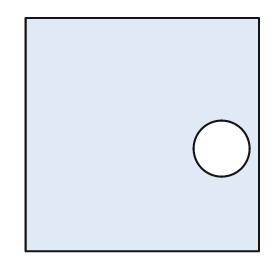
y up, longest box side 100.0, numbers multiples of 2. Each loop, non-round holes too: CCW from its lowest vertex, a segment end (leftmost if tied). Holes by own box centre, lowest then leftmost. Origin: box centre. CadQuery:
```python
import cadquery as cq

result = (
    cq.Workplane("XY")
    .moveTo(-50.0, -50.0)
    .lineTo(50.0, -50.0)
    .lineTo(50.0, 50.0)
    .lineTo(-50.0, 50.0)
    .close()
    .moveTo(34.0, -6.0)
    .circle(12.0)
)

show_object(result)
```